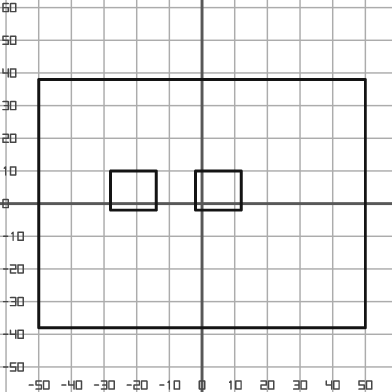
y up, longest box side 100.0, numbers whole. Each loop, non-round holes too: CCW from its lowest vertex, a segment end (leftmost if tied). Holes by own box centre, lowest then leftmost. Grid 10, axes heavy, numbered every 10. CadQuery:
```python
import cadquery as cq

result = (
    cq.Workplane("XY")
    .moveTo(-50.0, -38.0)
    .lineTo(50.0, -38.0)
    .lineTo(50.0, 38.0)
    .lineTo(-50.0, 38.0)
    .close()
    .moveTo(-28.0, -2.0)
    .lineTo(-14.0, -2.0)
    .lineTo(-14.0, 10.0)
    .lineTo(-28.0, 10.0)
    .close()
    .moveTo(-2.0, -2.0)
    .lineTo(12.0, -2.0)
    .lineTo(12.0, 10.0)
    .lineTo(-2.0, 10.0)
    .close()
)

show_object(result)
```